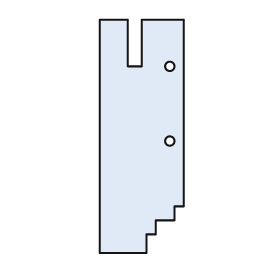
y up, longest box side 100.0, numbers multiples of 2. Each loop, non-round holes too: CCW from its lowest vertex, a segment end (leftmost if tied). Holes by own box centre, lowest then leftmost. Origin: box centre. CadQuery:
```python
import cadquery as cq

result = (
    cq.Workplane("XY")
    .moveTo(-18.0, -50.0)
    .lineTo(2.0, -50.0)
    .lineTo(2.0, -42.0)
    .lineTo(6.0, -42.0)
    .lineTo(6.0, -36.0)
    .lineTo(14.0, -36.0)
    .lineTo(14.0, -30.0)
    .lineTo(18.0, -30.0)
    .lineTo(18.0, 50.0)
    .lineTo(0.0, 50.0)
    .lineTo(0.0, 30.0)
    .lineTo(-6.0, 30.0)
    .lineTo(-6.0, 50.0)
    .lineTo(-18.0, 50.0)
    .close()
    .moveTo(12.0, -2.0)
    .circle(2.0)
    .moveTo(12.0, 30.0)
    .circle(2.0)
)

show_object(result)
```